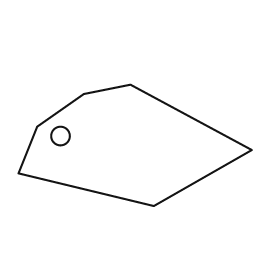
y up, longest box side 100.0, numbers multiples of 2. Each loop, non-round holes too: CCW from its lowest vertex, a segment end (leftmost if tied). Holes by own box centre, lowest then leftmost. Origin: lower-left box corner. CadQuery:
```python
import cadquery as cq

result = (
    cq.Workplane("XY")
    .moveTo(58.0, 0.0)
    .lineTo(100.0, 24.0)
    .lineTo(48.0, 52.0)
    .lineTo(28.0, 48.0)
    .lineTo(8.0, 34.0)
    .lineTo(0.0, 14.0)
    .close()
    .moveTo(18.0, 30.0)
    .circle(4.0)
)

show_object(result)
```